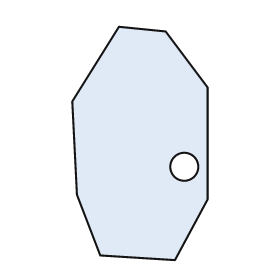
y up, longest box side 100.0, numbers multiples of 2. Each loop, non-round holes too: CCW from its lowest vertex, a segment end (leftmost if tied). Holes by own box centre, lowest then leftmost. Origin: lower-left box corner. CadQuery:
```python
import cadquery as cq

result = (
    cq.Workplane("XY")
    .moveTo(44.0, 0.0)
    .lineTo(58.0, 26.0)
    .lineTo(58.0, 74.0)
    .lineTo(40.0, 98.0)
    .lineTo(20.0, 100.0)
    .lineTo(0.0, 68.0)
    .lineTo(2.0, 28.0)
    .lineTo(12.0, 2.0)
    .close()
    .moveTo(48.0, 40.0)
    .circle(6.0)
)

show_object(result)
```